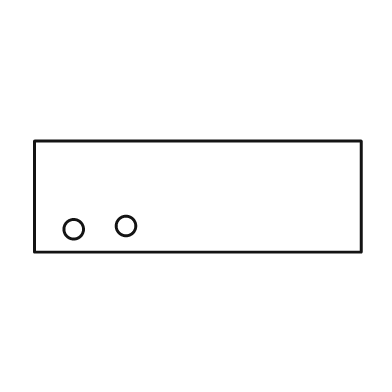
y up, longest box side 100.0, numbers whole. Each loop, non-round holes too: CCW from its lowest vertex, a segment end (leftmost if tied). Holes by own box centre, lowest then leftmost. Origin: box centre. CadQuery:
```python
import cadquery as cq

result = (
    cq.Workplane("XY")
    .moveTo(-50.0, -17.0)
    .lineTo(50.0, -17.0)
    .lineTo(50.0, 17.0)
    .lineTo(-50.0, 17.0)
    .close()
    .moveTo(-38.0, -10.0)
    .circle(3.0)
    .moveTo(-22.0, -9.0)
    .circle(3.0)
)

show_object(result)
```